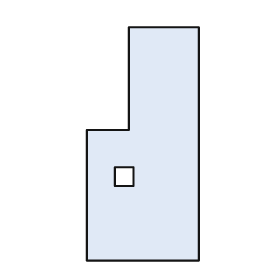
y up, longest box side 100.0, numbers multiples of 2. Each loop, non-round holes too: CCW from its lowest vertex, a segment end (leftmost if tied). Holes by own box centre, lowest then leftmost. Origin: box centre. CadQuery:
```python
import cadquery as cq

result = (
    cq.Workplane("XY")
    .moveTo(-24.0, -50.0)
    .lineTo(24.0, -50.0)
    .lineTo(24.0, 50.0)
    .lineTo(-6.0, 50.0)
    .lineTo(-6.0, 6.0)
    .lineTo(-24.0, 6.0)
    .close()
    .moveTo(-12.0, -18.0)
    .lineTo(-4.0, -18.0)
    .lineTo(-4.0, -10.0)
    .lineTo(-12.0, -10.0)
    .close()
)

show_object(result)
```